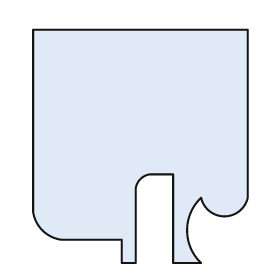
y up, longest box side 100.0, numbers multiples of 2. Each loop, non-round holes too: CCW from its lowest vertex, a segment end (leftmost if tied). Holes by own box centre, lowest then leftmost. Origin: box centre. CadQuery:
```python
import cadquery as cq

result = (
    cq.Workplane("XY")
    .moveTo(-8.0, -50.0)
    .lineTo(-2.0, -50.0)
    .lineTo(-2.0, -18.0)
    .threePointArc((0.0, -14.0), (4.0, -12.0))
    .lineTo(14.0, -12.0)
    .lineTo(14.0, -50.0)
    .lineTo(26.0, -50.0)
    .threePointArc((20.0, -36.0), (26.0, -22.0))
    .threePointArc((36.0, -30.0), (46.0, -22.0))
    .lineTo(46.0, 50.0)
    .lineTo(-46.0, 50.0)
    .lineTo(-46.0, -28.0)
    .threePointArc((-42.0, -36.0), (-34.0, -40.0))
    .lineTo(-8.0, -40.0)
    .close()
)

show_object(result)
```